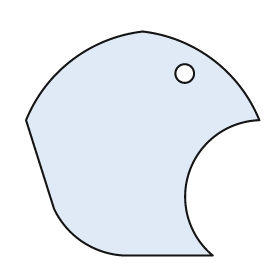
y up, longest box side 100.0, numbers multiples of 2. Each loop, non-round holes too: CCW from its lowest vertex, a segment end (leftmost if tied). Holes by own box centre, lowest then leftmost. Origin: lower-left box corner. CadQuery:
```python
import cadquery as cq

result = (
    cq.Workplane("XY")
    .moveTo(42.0, 0.0)
    .lineTo(80.0, 0.0)
    .threePointArc((70.0, 36.0), (100.0, 58.0))
    .threePointArc((80.0, 84.0), (50.0, 96.0))
    .threePointArc((20.0, 84.0), (0.0, 58.0))
    .lineTo(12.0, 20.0)
    .threePointArc((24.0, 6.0), (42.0, 0.0))
    .close()
    .moveTo(68.0, 78.0)
    .circle(4.0)
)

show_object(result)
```